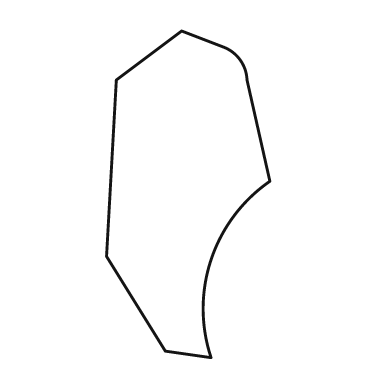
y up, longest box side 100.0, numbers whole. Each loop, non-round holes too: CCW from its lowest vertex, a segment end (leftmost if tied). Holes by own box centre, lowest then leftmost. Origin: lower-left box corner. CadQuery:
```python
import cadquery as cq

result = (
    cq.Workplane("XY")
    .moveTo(32.0, 0.0)
    .threePointArc((32.0, 30.0), (50.0, 54.0))
    .lineTo(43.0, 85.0)
    .threePointArc((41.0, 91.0), (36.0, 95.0))
    .lineTo(23.0, 100.0)
    .lineTo(3.0, 85.0)
    .lineTo(0.0, 31.0)
    .lineTo(18.0, 2.0)
    .close()
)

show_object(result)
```